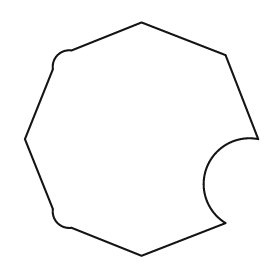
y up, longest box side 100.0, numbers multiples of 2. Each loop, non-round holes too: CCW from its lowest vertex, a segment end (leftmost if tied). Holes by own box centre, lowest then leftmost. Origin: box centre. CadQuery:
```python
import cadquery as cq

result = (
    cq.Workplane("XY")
    .moveTo(0.0, -50.0)
    .lineTo(36.0, -36.0)
    .threePointArc((28.0, -12.0), (50.0, 0.0))
    .lineTo(36.0, 36.0)
    .lineTo(0.0, 50.0)
    .lineTo(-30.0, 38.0)
    .threePointArc((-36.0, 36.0), (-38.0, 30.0))
    .lineTo(-50.0, 0.0)
    .lineTo(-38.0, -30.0)
    .threePointArc((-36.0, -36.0), (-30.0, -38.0))
    .close()
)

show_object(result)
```